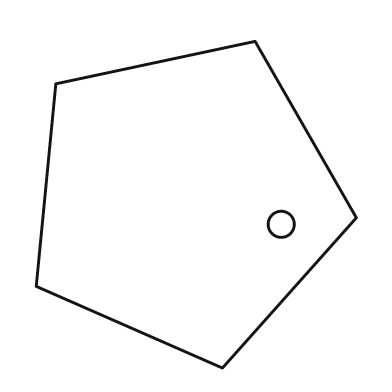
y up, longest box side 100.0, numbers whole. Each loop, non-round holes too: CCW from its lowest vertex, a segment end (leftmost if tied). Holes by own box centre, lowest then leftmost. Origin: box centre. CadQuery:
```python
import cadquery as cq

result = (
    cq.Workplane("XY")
    .moveTo(8.0, -50.0)
    .lineTo(49.0, -4.0)
    .lineTo(18.0, 50.0)
    .lineTo(-43.0, 37.0)
    .lineTo(-49.0, -25.0)
    .close()
    .moveTo(26.0, -6.0)
    .circle(4.0)
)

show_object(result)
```